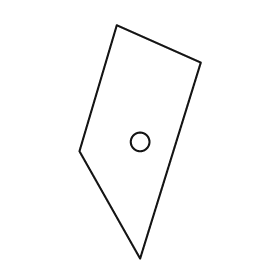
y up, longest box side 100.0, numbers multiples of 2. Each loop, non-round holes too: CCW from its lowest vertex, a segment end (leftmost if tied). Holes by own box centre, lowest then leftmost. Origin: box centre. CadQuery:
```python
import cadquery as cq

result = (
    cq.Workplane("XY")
    .moveTo(0.0, -50.0)
    .lineTo(26.0, 34.0)
    .lineTo(-10.0, 50.0)
    .lineTo(-26.0, -4.0)
    .close()
    .moveTo(0.0, 0.0)
    .circle(4.0)
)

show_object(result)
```